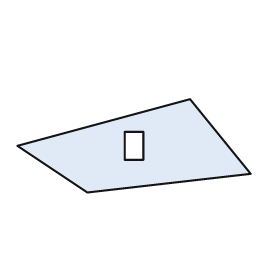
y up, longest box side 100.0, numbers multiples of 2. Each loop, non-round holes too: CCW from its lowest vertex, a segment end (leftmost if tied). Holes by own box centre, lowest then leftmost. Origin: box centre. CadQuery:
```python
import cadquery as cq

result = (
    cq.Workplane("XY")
    .moveTo(-20.0, -20.0)
    .lineTo(50.0, -12.0)
    .lineTo(24.0, 20.0)
    .lineTo(-50.0, 0.0)
    .close()
    .moveTo(-4.0, -6.0)
    .lineTo(4.0, -6.0)
    .lineTo(4.0, 6.0)
    .lineTo(-4.0, 6.0)
    .close()
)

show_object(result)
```